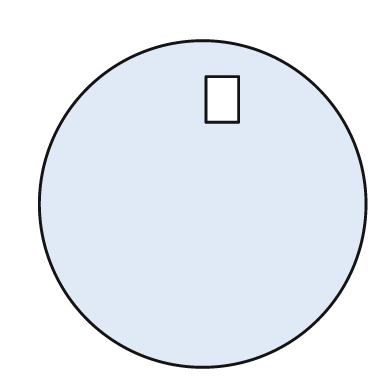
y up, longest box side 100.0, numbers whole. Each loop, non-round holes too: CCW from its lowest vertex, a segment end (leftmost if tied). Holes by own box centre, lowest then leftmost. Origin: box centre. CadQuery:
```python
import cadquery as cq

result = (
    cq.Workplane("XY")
    .moveTo(0.0, 0.0)
    .circle(50.0)
    .moveTo(1.0, 25.0)
    .lineTo(11.0, 25.0)
    .lineTo(11.0, 39.0)
    .lineTo(1.0, 39.0)
    .close()
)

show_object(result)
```